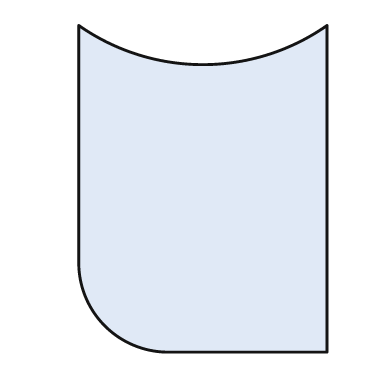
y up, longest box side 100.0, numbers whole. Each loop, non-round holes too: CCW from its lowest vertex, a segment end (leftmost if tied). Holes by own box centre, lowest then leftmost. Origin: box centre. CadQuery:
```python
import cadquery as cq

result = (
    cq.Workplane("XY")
    .moveTo(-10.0, -50.0)
    .lineTo(38.0, -50.0)
    .lineTo(38.0, 50.0)
    .threePointArc((0.0, 38.0), (-38.0, 50.0))
    .lineTo(-38.0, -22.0)
    .threePointArc((-30.0, -42.0), (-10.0, -50.0))
    .close()
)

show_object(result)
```